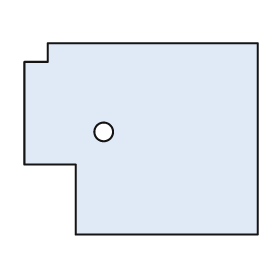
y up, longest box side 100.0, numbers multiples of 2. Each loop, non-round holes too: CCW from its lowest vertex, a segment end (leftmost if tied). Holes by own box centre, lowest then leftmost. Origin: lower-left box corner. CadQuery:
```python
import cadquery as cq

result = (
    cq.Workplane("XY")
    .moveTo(22.0, 0.0)
    .lineTo(100.0, 0.0)
    .lineTo(100.0, 82.0)
    .lineTo(10.0, 82.0)
    .lineTo(10.0, 74.0)
    .lineTo(0.0, 74.0)
    .lineTo(0.0, 30.0)
    .lineTo(22.0, 30.0)
    .close()
    .moveTo(34.0, 44.0)
    .circle(4.0)
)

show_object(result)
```